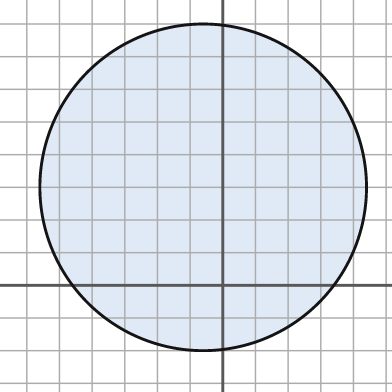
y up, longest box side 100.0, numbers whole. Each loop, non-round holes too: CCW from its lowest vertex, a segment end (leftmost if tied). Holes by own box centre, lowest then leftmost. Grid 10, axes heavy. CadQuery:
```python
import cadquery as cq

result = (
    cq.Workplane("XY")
    .moveTo(-6.0, 30.0)
    .circle(50.0)
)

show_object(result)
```